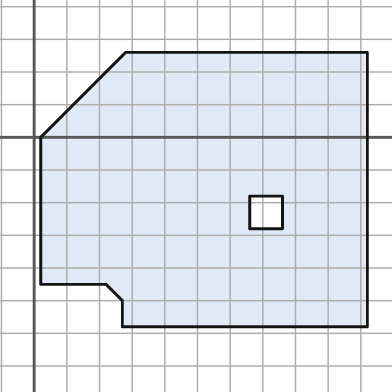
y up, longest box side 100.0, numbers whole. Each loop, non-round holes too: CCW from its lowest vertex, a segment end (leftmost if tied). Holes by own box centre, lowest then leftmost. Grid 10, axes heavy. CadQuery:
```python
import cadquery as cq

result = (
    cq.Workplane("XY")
    .moveTo(27.0, -58.0)
    .lineTo(102.0, -58.0)
    .lineTo(102.0, 26.0)
    .lineTo(28.0, 26.0)
    .lineTo(2.0, 0.0)
    .lineTo(2.0, -45.0)
    .lineTo(22.0, -45.0)
    .lineTo(27.0, -50.0)
    .close()
    .moveTo(66.0, -28.0)
    .lineTo(76.0, -28.0)
    .lineTo(76.0, -18.0)
    .lineTo(66.0, -18.0)
    .close()
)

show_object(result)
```